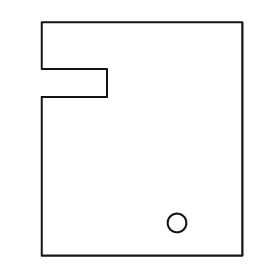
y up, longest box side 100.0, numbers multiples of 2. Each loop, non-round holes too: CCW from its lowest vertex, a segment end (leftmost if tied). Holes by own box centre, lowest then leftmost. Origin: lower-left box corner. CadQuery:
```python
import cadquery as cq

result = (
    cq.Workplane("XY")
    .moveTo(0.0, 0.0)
    .lineTo(86.0, 0.0)
    .lineTo(86.0, 100.0)
    .lineTo(0.0, 100.0)
    .lineTo(0.0, 80.0)
    .lineTo(28.0, 80.0)
    .lineTo(28.0, 68.0)
    .lineTo(0.0, 68.0)
    .close()
    .moveTo(58.0, 14.0)
    .circle(4.0)
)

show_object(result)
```